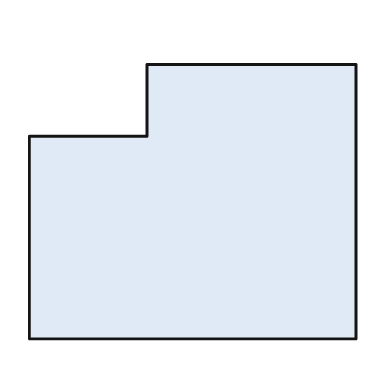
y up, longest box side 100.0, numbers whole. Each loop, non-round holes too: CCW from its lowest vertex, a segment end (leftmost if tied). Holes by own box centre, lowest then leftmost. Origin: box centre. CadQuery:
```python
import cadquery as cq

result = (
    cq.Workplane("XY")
    .moveTo(-50.0, -42.0)
    .lineTo(50.0, -42.0)
    .lineTo(50.0, 42.0)
    .lineTo(-14.0, 42.0)
    .lineTo(-14.0, 20.0)
    .lineTo(-50.0, 20.0)
    .close()
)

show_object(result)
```